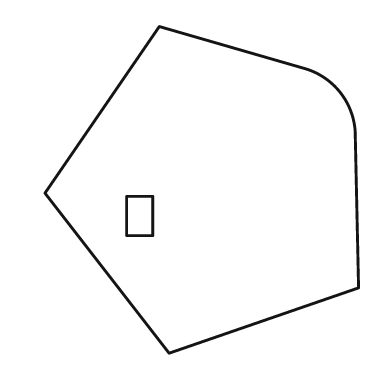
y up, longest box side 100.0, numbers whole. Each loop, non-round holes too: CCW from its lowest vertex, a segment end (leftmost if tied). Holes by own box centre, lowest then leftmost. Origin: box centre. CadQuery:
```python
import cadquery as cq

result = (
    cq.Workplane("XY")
    .moveTo(-10.0, -50.0)
    .lineTo(48.0, -30.0)
    .lineTo(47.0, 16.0)
    .threePointArc((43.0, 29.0), (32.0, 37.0))
    .lineTo(-13.0, 50.0)
    .lineTo(-48.0, -1.0)
    .close()
    .moveTo(-23.0, -14.0)
    .lineTo(-15.0, -14.0)
    .lineTo(-15.0, -2.0)
    .lineTo(-23.0, -2.0)
    .close()
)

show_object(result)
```